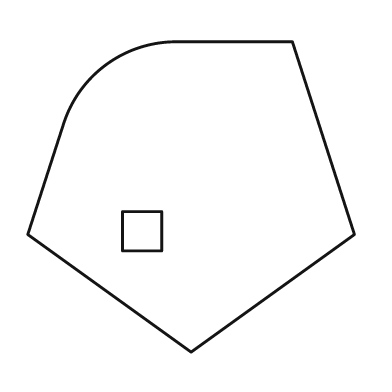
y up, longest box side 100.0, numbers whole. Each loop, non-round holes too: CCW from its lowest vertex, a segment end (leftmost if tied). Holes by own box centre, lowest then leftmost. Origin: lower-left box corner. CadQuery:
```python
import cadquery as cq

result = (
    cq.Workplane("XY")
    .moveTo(50.0, 0.0)
    .lineTo(100.0, 36.0)
    .lineTo(81.0, 95.0)
    .lineTo(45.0, 95.0)
    .threePointArc((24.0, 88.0), (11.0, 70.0))
    .lineTo(0.0, 36.0)
    .close()
    .moveTo(29.0, 31.0)
    .lineTo(41.0, 31.0)
    .lineTo(41.0, 43.0)
    .lineTo(29.0, 43.0)
    .close()
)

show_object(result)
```